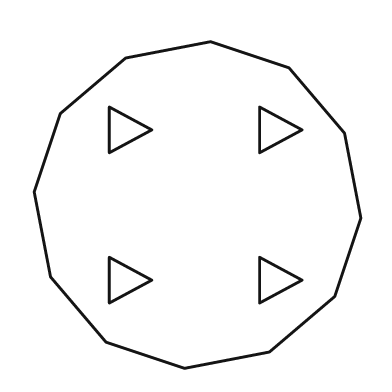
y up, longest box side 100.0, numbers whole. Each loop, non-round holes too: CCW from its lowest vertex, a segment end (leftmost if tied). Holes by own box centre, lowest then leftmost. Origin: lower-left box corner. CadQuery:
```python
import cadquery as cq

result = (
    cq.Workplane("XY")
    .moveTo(46.0, 0.0)
    .lineTo(72.0, 5.0)
    .lineTo(92.0, 22.0)
    .lineTo(100.0, 46.0)
    .lineTo(95.0, 72.0)
    .lineTo(78.0, 92.0)
    .lineTo(54.0, 100.0)
    .lineTo(28.0, 95.0)
    .lineTo(8.0, 78.0)
    .lineTo(0.0, 54.0)
    .lineTo(5.0, 28.0)
    .lineTo(22.0, 8.0)
    .close()
    .moveTo(23.0, 20.0)
    .lineTo(36.0, 27.0)
    .lineTo(23.0, 34.0)
    .close()
    .moveTo(69.0, 20.0)
    .lineTo(82.0, 27.0)
    .lineTo(69.0, 34.0)
    .close()
    .moveTo(23.0, 66.0)
    .lineTo(36.0, 73.0)
    .lineTo(23.0, 80.0)
    .close()
    .moveTo(69.0, 66.0)
    .lineTo(82.0, 73.0)
    .lineTo(69.0, 80.0)
    .close()
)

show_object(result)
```